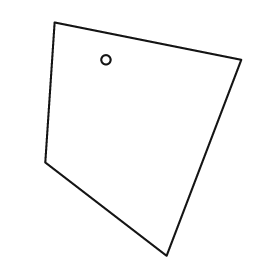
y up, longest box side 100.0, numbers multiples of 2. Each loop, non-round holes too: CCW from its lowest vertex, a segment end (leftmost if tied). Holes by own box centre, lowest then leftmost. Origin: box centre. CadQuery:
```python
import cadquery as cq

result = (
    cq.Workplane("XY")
    .moveTo(10.0, -50.0)
    .lineTo(42.0, 34.0)
    .lineTo(-38.0, 50.0)
    .lineTo(-42.0, -10.0)
    .close()
    .moveTo(-16.0, 34.0)
    .circle(2.0)
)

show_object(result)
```